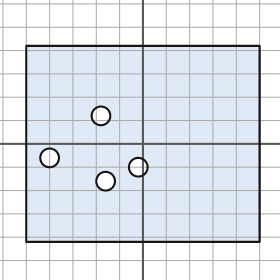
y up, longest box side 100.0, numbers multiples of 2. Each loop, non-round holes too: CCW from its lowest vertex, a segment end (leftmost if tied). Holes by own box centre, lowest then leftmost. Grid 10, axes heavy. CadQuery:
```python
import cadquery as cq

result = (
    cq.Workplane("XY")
    .moveTo(-50.0, -42.0)
    .lineTo(50.0, -42.0)
    .lineTo(50.0, 42.0)
    .lineTo(-50.0, 42.0)
    .close()
    .moveTo(-16.0, -16.0)
    .circle(4.0)
    .moveTo(-2.0, -10.0)
    .circle(4.0)
    .moveTo(-40.0, -6.0)
    .circle(4.0)
    .moveTo(-18.0, 12.0)
    .circle(4.0)
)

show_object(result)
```